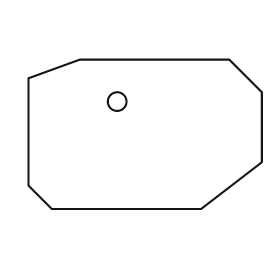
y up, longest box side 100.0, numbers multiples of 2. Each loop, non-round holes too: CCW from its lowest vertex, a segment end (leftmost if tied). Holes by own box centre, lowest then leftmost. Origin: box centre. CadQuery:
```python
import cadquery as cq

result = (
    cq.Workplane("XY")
    .moveTo(-40.0, -32.0)
    .lineTo(24.0, -32.0)
    .lineTo(50.0, -12.0)
    .lineTo(50.0, 18.0)
    .lineTo(36.0, 32.0)
    .lineTo(-28.0, 32.0)
    .lineTo(-50.0, 24.0)
    .lineTo(-50.0, -22.0)
    .close()
    .moveTo(-12.0, 14.0)
    .circle(4.0)
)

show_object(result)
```